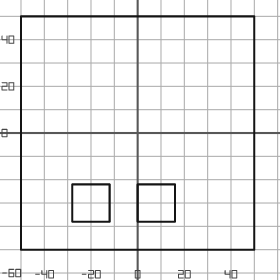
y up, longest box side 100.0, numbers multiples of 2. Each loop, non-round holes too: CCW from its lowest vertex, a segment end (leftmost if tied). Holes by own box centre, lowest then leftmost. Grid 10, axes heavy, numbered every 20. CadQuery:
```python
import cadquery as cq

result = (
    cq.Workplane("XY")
    .moveTo(-50.0, -50.0)
    .lineTo(50.0, -50.0)
    .lineTo(50.0, 50.0)
    .lineTo(-50.0, 50.0)
    .close()
    .moveTo(-28.0, -38.0)
    .lineTo(-12.0, -38.0)
    .lineTo(-12.0, -22.0)
    .lineTo(-28.0, -22.0)
    .close()
    .moveTo(0.0, -38.0)
    .lineTo(16.0, -38.0)
    .lineTo(16.0, -22.0)
    .lineTo(0.0, -22.0)
    .close()
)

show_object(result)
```